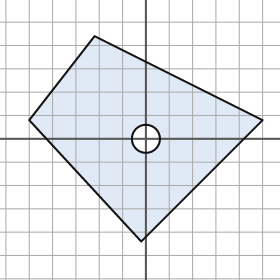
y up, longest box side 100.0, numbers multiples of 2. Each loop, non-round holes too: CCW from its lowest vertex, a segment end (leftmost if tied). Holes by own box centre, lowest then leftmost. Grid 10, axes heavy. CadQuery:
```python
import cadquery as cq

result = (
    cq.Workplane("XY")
    .moveTo(-2.0, -44.0)
    .lineTo(50.0, 8.0)
    .lineTo(-22.0, 44.0)
    .lineTo(-50.0, 8.0)
    .close()
    .moveTo(0.0, 0.0)
    .circle(6.0)
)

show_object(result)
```